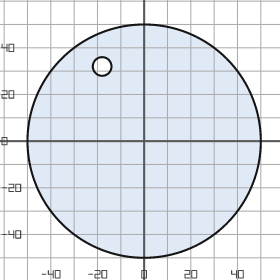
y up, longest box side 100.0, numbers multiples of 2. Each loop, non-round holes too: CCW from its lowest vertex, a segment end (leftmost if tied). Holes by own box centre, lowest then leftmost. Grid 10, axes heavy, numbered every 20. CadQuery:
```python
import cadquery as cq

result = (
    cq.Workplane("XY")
    .moveTo(0.0, 0.0)
    .circle(50.0)
    .moveTo(-18.0, 32.0)
    .circle(4.0)
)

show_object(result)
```